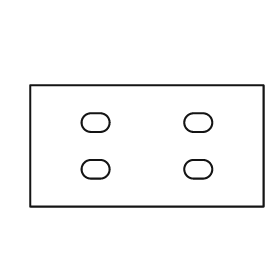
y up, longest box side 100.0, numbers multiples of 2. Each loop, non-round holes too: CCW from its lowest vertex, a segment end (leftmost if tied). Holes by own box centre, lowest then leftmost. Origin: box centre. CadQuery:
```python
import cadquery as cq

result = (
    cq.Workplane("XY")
    .moveTo(-50.0, -26.0)
    .lineTo(50.0, -26.0)
    .lineTo(50.0, 26.0)
    .lineTo(-50.0, 26.0)
    .close()
    .moveTo(-24.0, -14.0)
    .lineTo(-20.0, -14.0)
    .threePointArc((-16.0, -10.0), (-20.0, -6.0))
    .lineTo(-24.0, -6.0)
    .threePointArc((-28.0, -10.0), (-24.0, -14.0))
    .close()
    .moveTo(20.0, -14.0)
    .lineTo(24.0, -14.0)
    .threePointArc((28.0, -10.0), (24.0, -6.0))
    .lineTo(20.0, -6.0)
    .threePointArc((16.0, -10.0), (20.0, -14.0))
    .close()
    .moveTo(-24.0, 6.0)
    .lineTo(-20.0, 6.0)
    .threePointArc((-16.0, 10.0), (-20.0, 14.0))
    .lineTo(-24.0, 14.0)
    .threePointArc((-28.0, 10.0), (-24.0, 6.0))
    .close()
    .moveTo(20.0, 6.0)
    .lineTo(24.0, 6.0)
    .threePointArc((28.0, 10.0), (24.0, 14.0))
    .lineTo(20.0, 14.0)
    .threePointArc((16.0, 10.0), (20.0, 6.0))
    .close()
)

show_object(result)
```